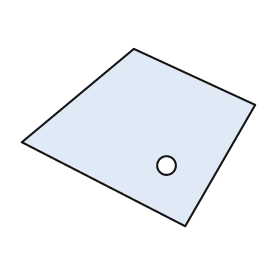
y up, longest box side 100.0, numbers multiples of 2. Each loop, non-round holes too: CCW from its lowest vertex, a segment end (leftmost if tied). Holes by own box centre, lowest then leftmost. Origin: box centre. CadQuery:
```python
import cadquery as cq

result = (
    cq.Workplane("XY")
    .moveTo(20.0, -38.0)
    .lineTo(50.0, 14.0)
    .lineTo(-2.0, 38.0)
    .lineTo(-50.0, -2.0)
    .close()
    .moveTo(12.0, -12.0)
    .circle(4.0)
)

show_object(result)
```